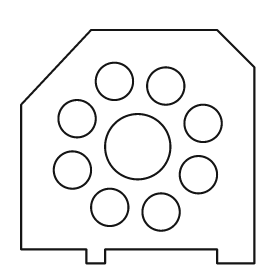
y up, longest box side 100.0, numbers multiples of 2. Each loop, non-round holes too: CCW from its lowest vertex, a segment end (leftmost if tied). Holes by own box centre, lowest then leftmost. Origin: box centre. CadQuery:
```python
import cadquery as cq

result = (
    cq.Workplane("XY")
    .moveTo(-22.0, -50.0)
    .lineTo(-14.0, -50.0)
    .lineTo(-14.0, -44.0)
    .lineTo(34.0, -44.0)
    .lineTo(34.0, -50.0)
    .lineTo(50.0, -50.0)
    .lineTo(50.0, 34.0)
    .lineTo(34.0, 50.0)
    .lineTo(-20.0, 50.0)
    .lineTo(-50.0, 18.0)
    .lineTo(-50.0, -44.0)
    .lineTo(-22.0, -44.0)
    .close()
    .moveTo(10.0, -28.0)
    .circle(8.0)
    .moveTo(-12.0, -26.0)
    .circle(8.0)
    .moveTo(26.0, -12.0)
    .circle(8.0)
    .moveTo(-28.0, -10.0)
    .circle(8.0)
    .moveTo(0.0, 0.0)
    .circle(14.0)
    .moveTo(28.0, 10.0)
    .circle(8.0)
    .moveTo(-26.0, 12.0)
    .circle(8.0)
    .moveTo(12.0, 26.0)
    .circle(8.0)
    .moveTo(-10.0, 28.0)
    .circle(8.0)
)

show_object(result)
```